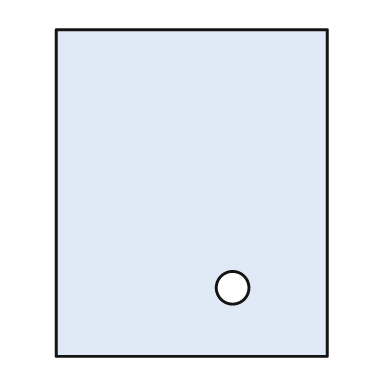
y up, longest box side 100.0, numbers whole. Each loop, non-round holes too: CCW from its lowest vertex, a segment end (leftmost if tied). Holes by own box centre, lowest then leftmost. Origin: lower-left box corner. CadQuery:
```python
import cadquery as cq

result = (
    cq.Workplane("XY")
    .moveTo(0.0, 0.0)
    .lineTo(83.0, 0.0)
    .lineTo(83.0, 100.0)
    .lineTo(0.0, 100.0)
    .close()
    .moveTo(54.0, 21.0)
    .circle(5.0)
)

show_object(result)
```